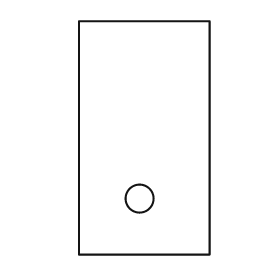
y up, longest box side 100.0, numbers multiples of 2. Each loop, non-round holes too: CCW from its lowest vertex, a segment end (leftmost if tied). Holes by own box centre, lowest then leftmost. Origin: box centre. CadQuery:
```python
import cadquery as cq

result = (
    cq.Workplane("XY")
    .moveTo(-28.0, -50.0)
    .lineTo(28.0, -50.0)
    .lineTo(28.0, 50.0)
    .lineTo(-28.0, 50.0)
    .close()
    .moveTo(-2.0, -26.0)
    .circle(6.0)
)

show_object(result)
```